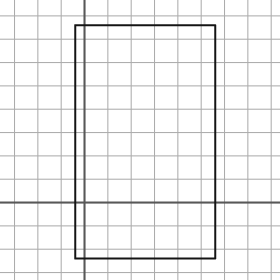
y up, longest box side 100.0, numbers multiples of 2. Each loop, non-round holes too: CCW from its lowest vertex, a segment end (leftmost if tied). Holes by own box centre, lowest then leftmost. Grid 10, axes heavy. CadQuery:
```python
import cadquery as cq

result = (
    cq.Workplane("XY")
    .moveTo(-4.0, -24.0)
    .lineTo(56.0, -24.0)
    .lineTo(56.0, 76.0)
    .lineTo(-4.0, 76.0)
    .close()
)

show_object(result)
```